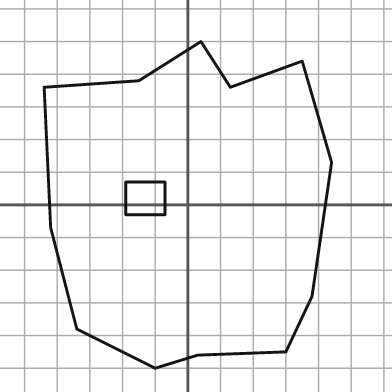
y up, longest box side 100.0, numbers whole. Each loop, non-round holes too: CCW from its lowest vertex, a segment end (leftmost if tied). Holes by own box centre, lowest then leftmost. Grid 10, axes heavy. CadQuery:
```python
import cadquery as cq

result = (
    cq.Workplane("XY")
    .moveTo(-10.0, -50.0)
    .lineTo(3.0, -46.0)
    .lineTo(30.0, -45.0)
    .lineTo(38.0, -28.0)
    .lineTo(44.0, 13.0)
    .lineTo(35.0, 44.0)
    .lineTo(13.0, 36.0)
    .lineTo(4.0, 50.0)
    .lineTo(-15.0, 38.0)
    .lineTo(-44.0, 36.0)
    .lineTo(-42.0, -7.0)
    .lineTo(-34.0, -38.0)
    .close()
    .moveTo(-19.0, -3.0)
    .lineTo(-7.0, -3.0)
    .lineTo(-7.0, 7.0)
    .lineTo(-19.0, 7.0)
    .close()
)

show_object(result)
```